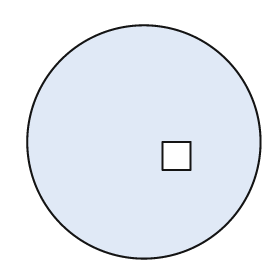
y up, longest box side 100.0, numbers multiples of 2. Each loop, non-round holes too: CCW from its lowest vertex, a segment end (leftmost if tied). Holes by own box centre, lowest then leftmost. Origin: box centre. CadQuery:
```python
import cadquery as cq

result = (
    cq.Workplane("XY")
    .moveTo(0.0, 0.0)
    .circle(50.0)
    .moveTo(8.0, -12.0)
    .lineTo(20.0, -12.0)
    .lineTo(20.0, 0.0)
    .lineTo(8.0, 0.0)
    .close()
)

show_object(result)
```